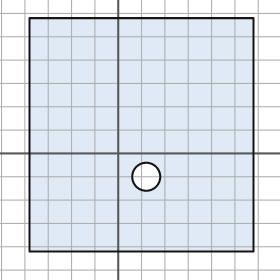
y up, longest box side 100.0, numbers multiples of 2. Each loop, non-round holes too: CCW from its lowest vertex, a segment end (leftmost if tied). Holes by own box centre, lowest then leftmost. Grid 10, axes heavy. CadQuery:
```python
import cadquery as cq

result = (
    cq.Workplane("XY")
    .moveTo(-38.0, -42.0)
    .lineTo(58.0, -42.0)
    .lineTo(58.0, 58.0)
    .lineTo(-38.0, 58.0)
    .close()
    .moveTo(12.0, -10.0)
    .circle(6.0)
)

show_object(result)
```